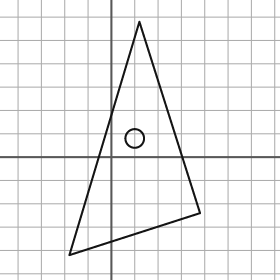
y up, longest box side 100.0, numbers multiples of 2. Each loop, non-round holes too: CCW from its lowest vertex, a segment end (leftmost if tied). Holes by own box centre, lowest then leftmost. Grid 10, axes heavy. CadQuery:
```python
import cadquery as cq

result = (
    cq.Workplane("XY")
    .moveTo(-18.0, -42.0)
    .lineTo(38.0, -24.0)
    .lineTo(12.0, 58.0)
    .close()
    .moveTo(10.0, 8.0)
    .circle(4.0)
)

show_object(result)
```